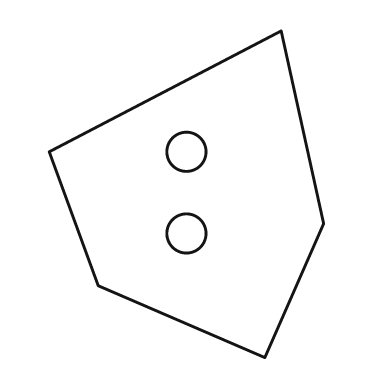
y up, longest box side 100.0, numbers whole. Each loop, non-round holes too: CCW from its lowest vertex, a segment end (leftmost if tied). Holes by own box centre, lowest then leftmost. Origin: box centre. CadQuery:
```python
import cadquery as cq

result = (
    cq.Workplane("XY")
    .moveTo(24.0, -50.0)
    .lineTo(42.0, -9.0)
    .lineTo(29.0, 50.0)
    .lineTo(-42.0, 13.0)
    .lineTo(-27.0, -28.0)
    .close()
    .moveTo(0.0, -12.0)
    .circle(6.0)
    .moveTo(0.0, 13.0)
    .circle(6.0)
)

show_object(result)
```